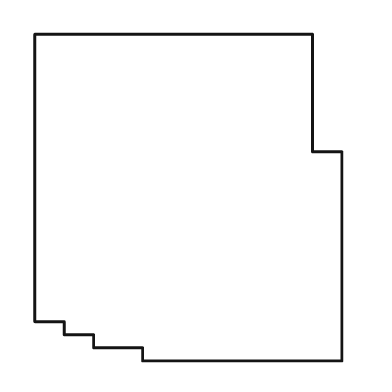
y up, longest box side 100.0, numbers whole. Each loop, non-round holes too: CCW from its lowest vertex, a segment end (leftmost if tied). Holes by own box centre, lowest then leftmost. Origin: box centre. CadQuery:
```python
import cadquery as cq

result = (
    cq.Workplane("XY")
    .moveTo(-14.0, -50.0)
    .lineTo(47.0, -50.0)
    .lineTo(47.0, 14.0)
    .lineTo(38.0, 14.0)
    .lineTo(38.0, 50.0)
    .lineTo(-47.0, 50.0)
    .lineTo(-47.0, -38.0)
    .lineTo(-38.0, -38.0)
    .lineTo(-38.0, -42.0)
    .lineTo(-29.0, -42.0)
    .lineTo(-29.0, -46.0)
    .lineTo(-14.0, -46.0)
    .close()
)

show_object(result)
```